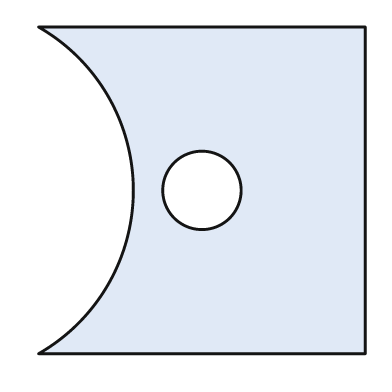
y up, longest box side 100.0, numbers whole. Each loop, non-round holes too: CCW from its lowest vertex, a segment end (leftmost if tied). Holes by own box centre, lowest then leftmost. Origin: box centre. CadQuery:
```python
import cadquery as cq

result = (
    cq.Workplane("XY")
    .moveTo(-50.0, -50.0)
    .lineTo(50.0, -50.0)
    .lineTo(50.0, 50.0)
    .lineTo(-50.0, 50.0)
    .threePointArc((-21.0, 0.0), (-50.0, -50.0))
    .close()
    .moveTo(0.0, 0.0)
    .circle(12.0)
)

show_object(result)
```